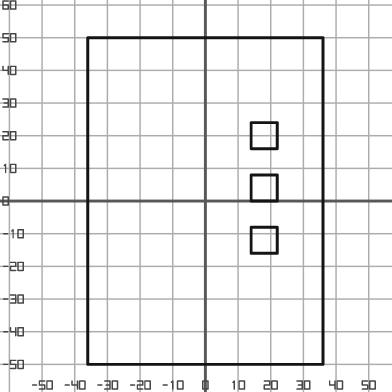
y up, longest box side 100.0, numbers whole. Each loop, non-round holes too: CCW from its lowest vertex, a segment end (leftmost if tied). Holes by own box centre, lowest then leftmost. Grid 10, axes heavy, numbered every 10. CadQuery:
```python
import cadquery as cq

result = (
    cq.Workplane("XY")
    .moveTo(-36.0, -50.0)
    .lineTo(36.0, -50.0)
    .lineTo(36.0, 50.0)
    .lineTo(-36.0, 50.0)
    .close()
    .moveTo(14.0, -16.0)
    .lineTo(22.0, -16.0)
    .lineTo(22.0, -8.0)
    .lineTo(14.0, -8.0)
    .close()
    .moveTo(14.0, 0.0)
    .lineTo(22.0, 0.0)
    .lineTo(22.0, 8.0)
    .lineTo(14.0, 8.0)
    .close()
    .moveTo(14.0, 16.0)
    .lineTo(22.0, 16.0)
    .lineTo(22.0, 24.0)
    .lineTo(14.0, 24.0)
    .close()
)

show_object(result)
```